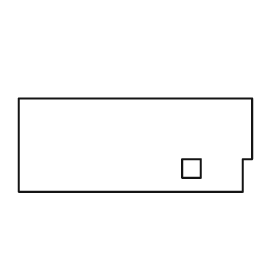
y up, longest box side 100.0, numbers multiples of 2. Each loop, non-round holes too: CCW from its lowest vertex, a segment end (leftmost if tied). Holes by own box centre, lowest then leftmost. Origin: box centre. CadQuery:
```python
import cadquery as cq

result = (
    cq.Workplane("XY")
    .moveTo(-50.0, -20.0)
    .lineTo(46.0, -20.0)
    .lineTo(46.0, -6.0)
    .lineTo(50.0, -6.0)
    .lineTo(50.0, 20.0)
    .lineTo(-50.0, 20.0)
    .close()
    .moveTo(20.0, -14.0)
    .lineTo(28.0, -14.0)
    .lineTo(28.0, -6.0)
    .lineTo(20.0, -6.0)
    .close()
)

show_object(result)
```